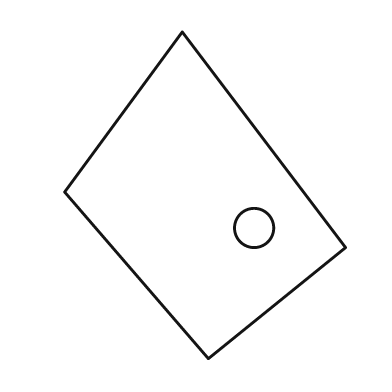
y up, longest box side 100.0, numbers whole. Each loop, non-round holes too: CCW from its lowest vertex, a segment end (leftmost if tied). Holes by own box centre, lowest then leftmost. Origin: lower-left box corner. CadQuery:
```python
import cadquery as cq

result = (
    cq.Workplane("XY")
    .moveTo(44.0, 0.0)
    .lineTo(86.0, 34.0)
    .lineTo(36.0, 100.0)
    .lineTo(0.0, 51.0)
    .close()
    .moveTo(58.0, 40.0)
    .circle(6.0)
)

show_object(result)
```